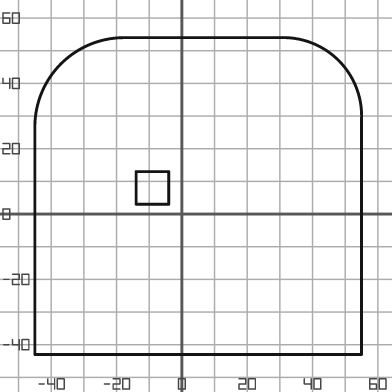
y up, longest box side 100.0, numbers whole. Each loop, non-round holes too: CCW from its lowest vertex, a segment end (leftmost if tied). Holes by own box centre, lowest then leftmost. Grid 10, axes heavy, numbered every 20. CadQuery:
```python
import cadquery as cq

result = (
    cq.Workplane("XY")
    .moveTo(-45.0, -43.0)
    .lineTo(55.0, -43.0)
    .lineTo(55.0, 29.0)
    .threePointArc((48.0, 47.0), (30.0, 54.0))
    .lineTo(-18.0, 54.0)
    .threePointArc((-37.0, 46.0), (-45.0, 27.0))
    .close()
    .moveTo(-14.0, 3.0)
    .lineTo(-4.0, 3.0)
    .lineTo(-4.0, 13.0)
    .lineTo(-14.0, 13.0)
    .close()
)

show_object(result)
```